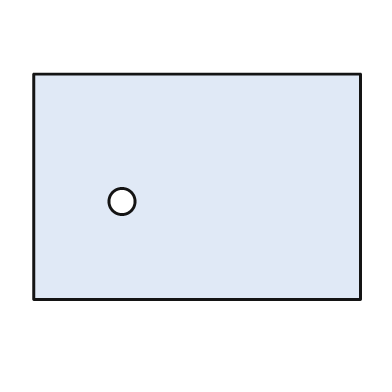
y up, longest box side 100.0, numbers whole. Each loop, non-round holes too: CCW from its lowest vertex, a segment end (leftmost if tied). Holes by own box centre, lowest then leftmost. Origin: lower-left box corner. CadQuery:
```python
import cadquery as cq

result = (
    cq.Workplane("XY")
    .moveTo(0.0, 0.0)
    .lineTo(100.0, 0.0)
    .lineTo(100.0, 69.0)
    .lineTo(0.0, 69.0)
    .close()
    .moveTo(27.0, 30.0)
    .circle(4.0)
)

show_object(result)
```